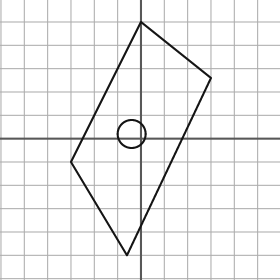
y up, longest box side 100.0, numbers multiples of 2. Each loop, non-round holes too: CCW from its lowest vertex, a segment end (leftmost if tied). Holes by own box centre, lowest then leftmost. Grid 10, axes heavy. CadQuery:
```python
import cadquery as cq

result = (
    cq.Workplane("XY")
    .moveTo(-6.0, -50.0)
    .lineTo(30.0, 26.0)
    .lineTo(0.0, 50.0)
    .lineTo(-30.0, -10.0)
    .close()
    .moveTo(-4.0, 2.0)
    .circle(6.0)
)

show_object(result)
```